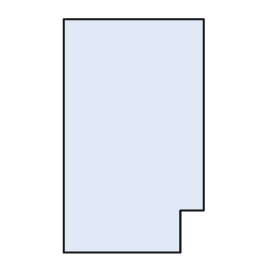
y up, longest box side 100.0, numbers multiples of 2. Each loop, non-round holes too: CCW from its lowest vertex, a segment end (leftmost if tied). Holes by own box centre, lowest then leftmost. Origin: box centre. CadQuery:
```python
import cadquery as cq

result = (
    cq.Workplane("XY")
    .moveTo(-30.0, -50.0)
    .lineTo(20.0, -50.0)
    .lineTo(20.0, -32.0)
    .lineTo(30.0, -32.0)
    .lineTo(30.0, 50.0)
    .lineTo(-30.0, 50.0)
    .close()
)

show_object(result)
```